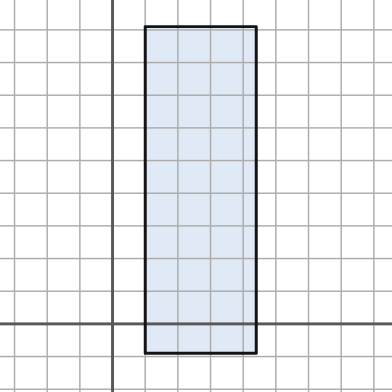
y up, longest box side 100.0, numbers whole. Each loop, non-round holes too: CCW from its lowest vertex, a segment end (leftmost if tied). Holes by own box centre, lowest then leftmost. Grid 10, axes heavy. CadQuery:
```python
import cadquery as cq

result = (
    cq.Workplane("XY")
    .moveTo(10.0, -9.0)
    .lineTo(44.0, -9.0)
    .lineTo(44.0, 91.0)
    .lineTo(10.0, 91.0)
    .close()
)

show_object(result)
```